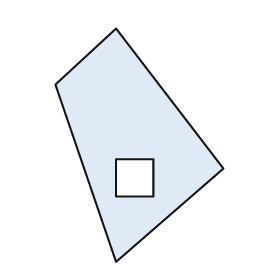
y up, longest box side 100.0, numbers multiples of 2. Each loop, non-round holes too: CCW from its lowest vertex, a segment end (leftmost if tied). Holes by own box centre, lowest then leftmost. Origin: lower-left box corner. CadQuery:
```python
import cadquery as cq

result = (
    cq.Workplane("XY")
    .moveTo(26.0, 0.0)
    .lineTo(72.0, 40.0)
    .lineTo(26.0, 100.0)
    .lineTo(0.0, 76.0)
    .close()
    .moveTo(26.0, 28.0)
    .lineTo(42.0, 28.0)
    .lineTo(42.0, 44.0)
    .lineTo(26.0, 44.0)
    .close()
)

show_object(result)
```